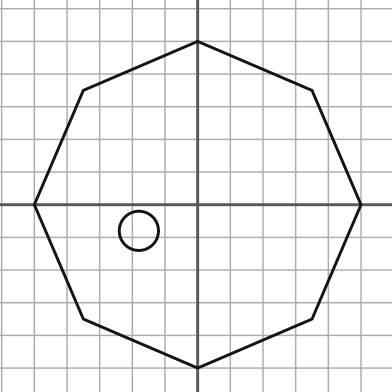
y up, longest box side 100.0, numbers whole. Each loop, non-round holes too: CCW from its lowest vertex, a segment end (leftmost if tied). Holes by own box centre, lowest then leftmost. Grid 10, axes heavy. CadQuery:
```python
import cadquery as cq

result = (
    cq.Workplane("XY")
    .moveTo(0.0, -50.0)
    .lineTo(35.0, -35.0)
    .lineTo(50.0, 0.0)
    .lineTo(35.0, 35.0)
    .lineTo(0.0, 50.0)
    .lineTo(-35.0, 35.0)
    .lineTo(-50.0, 0.0)
    .lineTo(-35.0, -35.0)
    .close()
    .moveTo(-18.0, -8.0)
    .circle(6.0)
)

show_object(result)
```